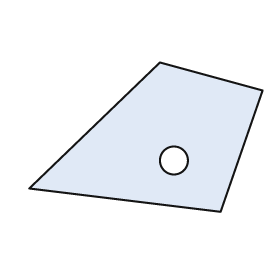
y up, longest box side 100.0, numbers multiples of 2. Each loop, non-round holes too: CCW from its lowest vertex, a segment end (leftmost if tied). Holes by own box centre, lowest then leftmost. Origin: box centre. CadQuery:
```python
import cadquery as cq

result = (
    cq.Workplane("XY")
    .moveTo(32.0, -32.0)
    .lineTo(50.0, 20.0)
    .lineTo(6.0, 32.0)
    .lineTo(-50.0, -22.0)
    .close()
    .moveTo(12.0, -10.0)
    .circle(6.0)
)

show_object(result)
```